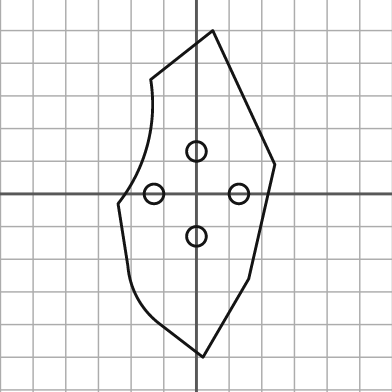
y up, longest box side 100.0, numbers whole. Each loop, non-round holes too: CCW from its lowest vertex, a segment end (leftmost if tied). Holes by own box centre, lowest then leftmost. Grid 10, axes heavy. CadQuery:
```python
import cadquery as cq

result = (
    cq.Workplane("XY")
    .moveTo(2.0, -50.0)
    .lineTo(16.0, -26.0)
    .lineTo(24.0, 9.0)
    .lineTo(5.0, 50.0)
    .lineTo(-14.0, 35.0)
    .threePointArc((-15.0, 15.0), (-24.0, -3.0))
    .lineTo(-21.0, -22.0)
    .threePointArc((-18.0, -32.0), (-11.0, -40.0))
    .close()
    .moveTo(0.0, -13.0)
    .circle(3.0)
    .moveTo(-13.0, 0.0)
    .circle(3.0)
    .moveTo(13.0, 0.0)
    .circle(3.0)
    .moveTo(0.0, 13.0)
    .circle(3.0)
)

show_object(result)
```